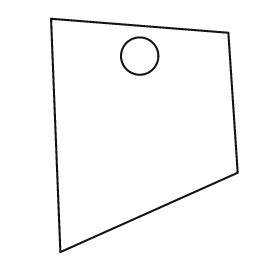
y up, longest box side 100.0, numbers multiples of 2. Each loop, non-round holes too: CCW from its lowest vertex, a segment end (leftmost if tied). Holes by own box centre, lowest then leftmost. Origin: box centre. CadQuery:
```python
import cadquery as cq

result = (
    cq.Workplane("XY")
    .moveTo(-36.0, -50.0)
    .lineTo(40.0, -16.0)
    .lineTo(36.0, 44.0)
    .lineTo(-40.0, 50.0)
    .close()
    .moveTo(-2.0, 34.0)
    .circle(8.0)
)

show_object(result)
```